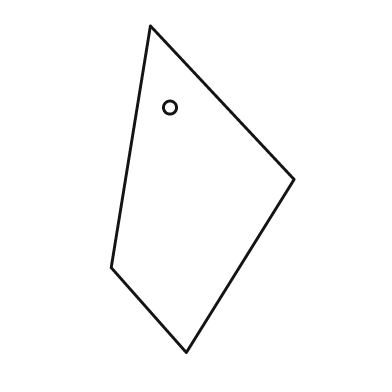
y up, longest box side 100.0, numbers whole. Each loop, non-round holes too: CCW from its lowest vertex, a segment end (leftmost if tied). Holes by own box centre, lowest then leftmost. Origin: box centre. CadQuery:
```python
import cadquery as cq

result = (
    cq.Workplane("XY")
    .moveTo(-5.0, -50.0)
    .lineTo(28.0, 3.0)
    .lineTo(-16.0, 50.0)
    .lineTo(-28.0, -24.0)
    .close()
    .moveTo(-10.0, 25.0)
    .circle(2.0)
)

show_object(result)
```